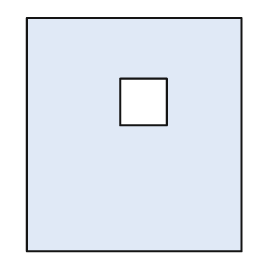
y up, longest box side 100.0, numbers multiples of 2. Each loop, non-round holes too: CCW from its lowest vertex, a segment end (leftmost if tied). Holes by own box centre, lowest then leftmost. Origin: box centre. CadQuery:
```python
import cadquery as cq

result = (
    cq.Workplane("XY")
    .moveTo(-46.0, -50.0)
    .lineTo(46.0, -50.0)
    .lineTo(46.0, 50.0)
    .lineTo(-46.0, 50.0)
    .close()
    .moveTo(-6.0, 4.0)
    .lineTo(14.0, 4.0)
    .lineTo(14.0, 24.0)
    .lineTo(-6.0, 24.0)
    .close()
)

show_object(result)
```